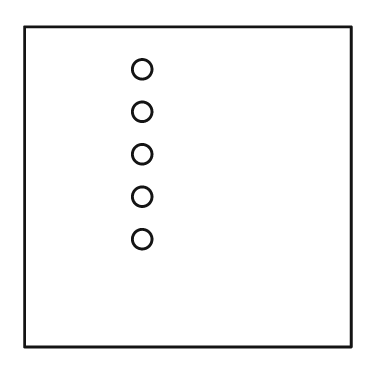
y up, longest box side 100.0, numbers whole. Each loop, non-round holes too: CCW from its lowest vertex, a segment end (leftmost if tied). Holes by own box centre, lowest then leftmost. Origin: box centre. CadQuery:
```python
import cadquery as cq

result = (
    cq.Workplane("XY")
    .moveTo(-50.0, -49.0)
    .lineTo(50.0, -49.0)
    .lineTo(50.0, 49.0)
    .lineTo(-50.0, 49.0)
    .close()
    .moveTo(-14.0, -16.0)
    .circle(3.0)
    .moveTo(-14.0, -3.0)
    .circle(3.0)
    .moveTo(-14.0, 10.0)
    .circle(3.0)
    .moveTo(-14.0, 23.0)
    .circle(3.0)
    .moveTo(-14.0, 36.0)
    .circle(3.0)
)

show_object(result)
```